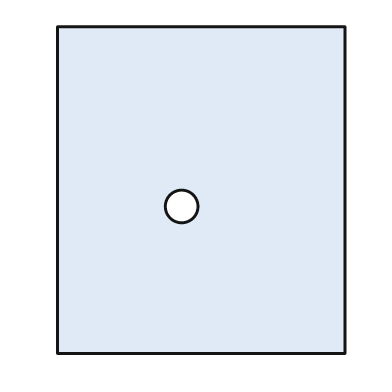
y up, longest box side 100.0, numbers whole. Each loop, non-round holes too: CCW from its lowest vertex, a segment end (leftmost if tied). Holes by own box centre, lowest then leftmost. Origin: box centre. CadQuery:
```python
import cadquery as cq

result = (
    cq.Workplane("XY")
    .moveTo(-44.0, -50.0)
    .lineTo(44.0, -50.0)
    .lineTo(44.0, 50.0)
    .lineTo(-44.0, 50.0)
    .close()
    .moveTo(-6.0, -5.0)
    .circle(5.0)
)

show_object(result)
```